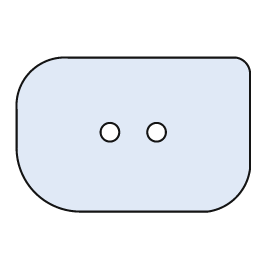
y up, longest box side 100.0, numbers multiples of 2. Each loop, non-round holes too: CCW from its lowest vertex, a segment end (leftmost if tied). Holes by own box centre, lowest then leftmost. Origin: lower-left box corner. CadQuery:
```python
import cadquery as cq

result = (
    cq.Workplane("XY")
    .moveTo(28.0, 0.0)
    .lineTo(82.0, 0.0)
    .threePointArc((94.0, 6.0), (100.0, 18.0))
    .lineTo(100.0, 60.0)
    .threePointArc((98.0, 64.0), (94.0, 66.0))
    .lineTo(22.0, 66.0)
    .threePointArc((6.0, 60.0), (0.0, 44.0))
    .lineTo(0.0, 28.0)
    .threePointArc((8.0, 8.0), (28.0, 0.0))
    .close()
    .moveTo(40.0, 34.0)
    .circle(4.0)
    .moveTo(60.0, 34.0)
    .circle(4.0)
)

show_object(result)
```